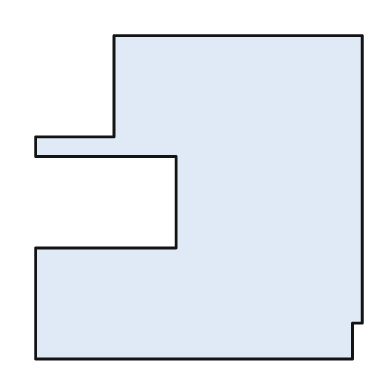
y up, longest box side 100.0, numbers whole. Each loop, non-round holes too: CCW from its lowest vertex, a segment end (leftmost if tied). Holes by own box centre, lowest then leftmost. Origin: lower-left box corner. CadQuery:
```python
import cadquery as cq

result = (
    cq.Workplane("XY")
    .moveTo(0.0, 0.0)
    .lineTo(97.0, 0.0)
    .lineTo(97.0, 11.0)
    .lineTo(100.0, 11.0)
    .lineTo(100.0, 99.0)
    .lineTo(24.0, 99.0)
    .lineTo(24.0, 68.0)
    .lineTo(0.0, 68.0)
    .lineTo(0.0, 62.0)
    .lineTo(43.0, 62.0)
    .lineTo(43.0, 34.0)
    .lineTo(0.0, 34.0)
    .close()
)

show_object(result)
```